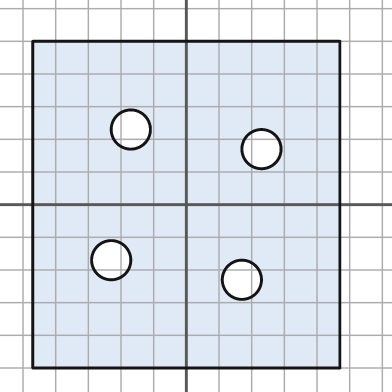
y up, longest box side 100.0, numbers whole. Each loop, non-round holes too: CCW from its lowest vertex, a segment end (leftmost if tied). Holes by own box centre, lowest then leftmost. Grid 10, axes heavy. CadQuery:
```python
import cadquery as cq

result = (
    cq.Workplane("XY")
    .moveTo(-47.0, -50.0)
    .lineTo(47.0, -50.0)
    .lineTo(47.0, 50.0)
    .lineTo(-47.0, 50.0)
    .close()
    .moveTo(17.0, -23.0)
    .circle(6.0)
    .moveTo(-23.0, -17.0)
    .circle(6.0)
    .moveTo(23.0, 17.0)
    .circle(6.0)
    .moveTo(-17.0, 23.0)
    .circle(6.0)
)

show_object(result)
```